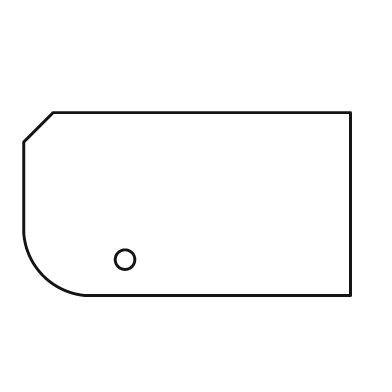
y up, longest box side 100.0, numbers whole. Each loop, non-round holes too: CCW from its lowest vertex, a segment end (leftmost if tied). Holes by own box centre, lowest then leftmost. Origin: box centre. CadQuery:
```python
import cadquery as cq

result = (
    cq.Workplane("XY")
    .moveTo(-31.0, -28.0)
    .lineTo(50.0, -28.0)
    .lineTo(50.0, 28.0)
    .lineTo(-41.0, 28.0)
    .lineTo(-50.0, 19.0)
    .lineTo(-50.0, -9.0)
    .threePointArc((-44.0, -22.0), (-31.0, -28.0))
    .close()
    .moveTo(-19.0, -17.0)
    .circle(3.0)
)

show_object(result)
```